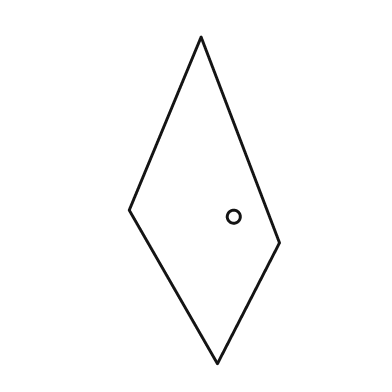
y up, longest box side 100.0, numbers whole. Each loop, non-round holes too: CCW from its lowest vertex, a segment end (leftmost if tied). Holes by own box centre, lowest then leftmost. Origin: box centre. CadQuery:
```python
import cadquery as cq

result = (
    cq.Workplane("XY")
    .moveTo(4.0, -50.0)
    .lineTo(23.0, -13.0)
    .lineTo(-1.0, 50.0)
    .lineTo(-23.0, -3.0)
    .close()
    .moveTo(9.0, -5.0)
    .circle(2.0)
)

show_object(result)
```